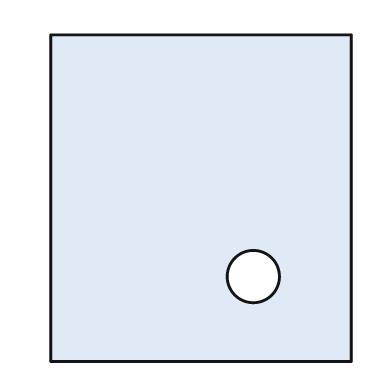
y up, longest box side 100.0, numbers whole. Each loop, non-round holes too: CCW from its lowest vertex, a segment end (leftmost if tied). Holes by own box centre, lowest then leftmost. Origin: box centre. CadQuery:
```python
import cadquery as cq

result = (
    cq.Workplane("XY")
    .moveTo(-46.0, -50.0)
    .lineTo(46.0, -50.0)
    .lineTo(46.0, 50.0)
    .lineTo(-46.0, 50.0)
    .close()
    .moveTo(16.0, -24.0)
    .circle(8.0)
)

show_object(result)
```